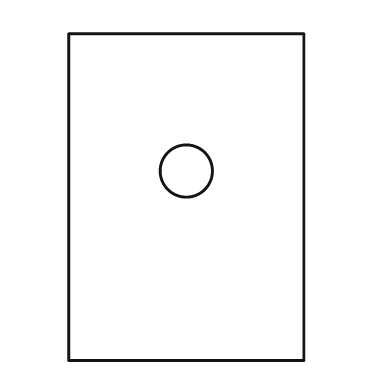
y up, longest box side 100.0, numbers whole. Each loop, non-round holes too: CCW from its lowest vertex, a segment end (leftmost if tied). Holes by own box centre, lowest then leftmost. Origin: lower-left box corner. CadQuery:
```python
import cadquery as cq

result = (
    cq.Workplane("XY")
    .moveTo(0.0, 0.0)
    .lineTo(72.0, 0.0)
    .lineTo(72.0, 100.0)
    .lineTo(0.0, 100.0)
    .close()
    .moveTo(36.0, 58.0)
    .circle(8.0)
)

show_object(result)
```